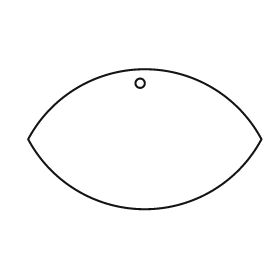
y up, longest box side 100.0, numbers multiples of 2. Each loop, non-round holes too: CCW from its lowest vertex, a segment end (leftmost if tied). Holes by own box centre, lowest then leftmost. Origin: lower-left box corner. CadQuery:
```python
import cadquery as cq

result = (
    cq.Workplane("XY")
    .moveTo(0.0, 30.0)
    .threePointArc((50.0, 0.0), (100.0, 30.0))
    .threePointArc((50.0, 60.0), (0.0, 30.0))
    .close()
    .moveTo(48.0, 54.0)
    .circle(2.0)
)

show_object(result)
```